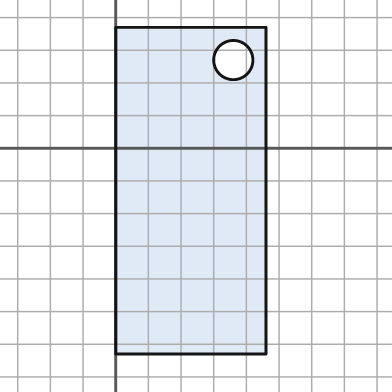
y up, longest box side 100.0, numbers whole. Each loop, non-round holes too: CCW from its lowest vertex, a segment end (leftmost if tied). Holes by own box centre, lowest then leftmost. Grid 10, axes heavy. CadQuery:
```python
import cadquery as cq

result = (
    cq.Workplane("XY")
    .moveTo(0.0, -63.0)
    .lineTo(46.0, -63.0)
    .lineTo(46.0, 37.0)
    .lineTo(0.0, 37.0)
    .close()
    .moveTo(36.0, 27.0)
    .circle(6.0)
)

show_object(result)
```